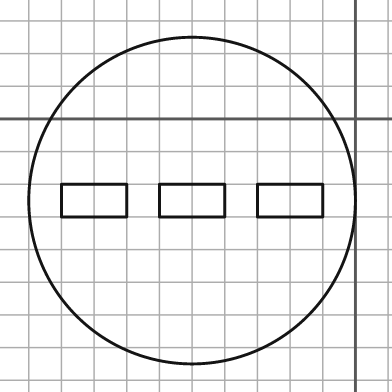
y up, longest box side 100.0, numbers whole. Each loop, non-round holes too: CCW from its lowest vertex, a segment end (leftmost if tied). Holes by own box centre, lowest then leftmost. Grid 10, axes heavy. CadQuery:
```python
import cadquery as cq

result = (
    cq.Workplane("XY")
    .moveTo(-50.0, -25.0)
    .circle(50.0)
    .moveTo(-90.0, -30.0)
    .lineTo(-70.0, -30.0)
    .lineTo(-70.0, -20.0)
    .lineTo(-90.0, -20.0)
    .close()
    .moveTo(-60.0, -30.0)
    .lineTo(-40.0, -30.0)
    .lineTo(-40.0, -20.0)
    .lineTo(-60.0, -20.0)
    .close()
    .moveTo(-30.0, -30.0)
    .lineTo(-10.0, -30.0)
    .lineTo(-10.0, -20.0)
    .lineTo(-30.0, -20.0)
    .close()
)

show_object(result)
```